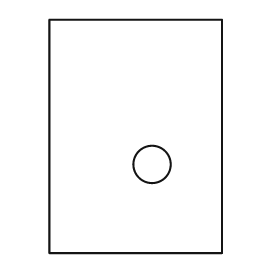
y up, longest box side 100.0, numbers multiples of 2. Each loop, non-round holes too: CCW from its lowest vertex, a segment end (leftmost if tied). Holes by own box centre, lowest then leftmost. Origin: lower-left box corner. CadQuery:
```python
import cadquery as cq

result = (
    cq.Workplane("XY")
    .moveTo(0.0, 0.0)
    .lineTo(74.0, 0.0)
    .lineTo(74.0, 100.0)
    .lineTo(0.0, 100.0)
    .close()
    .moveTo(44.0, 38.0)
    .circle(8.0)
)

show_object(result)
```